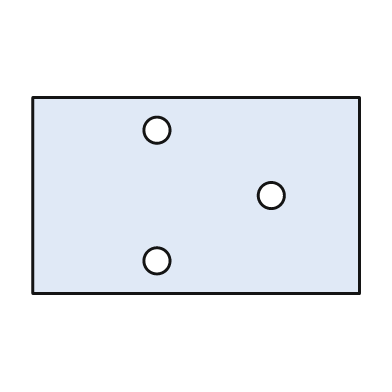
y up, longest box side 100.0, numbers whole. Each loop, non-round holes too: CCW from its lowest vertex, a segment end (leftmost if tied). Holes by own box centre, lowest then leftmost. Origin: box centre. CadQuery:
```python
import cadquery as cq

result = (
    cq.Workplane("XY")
    .moveTo(-50.0, -30.0)
    .lineTo(50.0, -30.0)
    .lineTo(50.0, 30.0)
    .lineTo(-50.0, 30.0)
    .close()
    .moveTo(-12.0, -20.0)
    .circle(4.0)
    .moveTo(23.0, 0.0)
    .circle(4.0)
    .moveTo(-12.0, 20.0)
    .circle(4.0)
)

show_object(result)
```